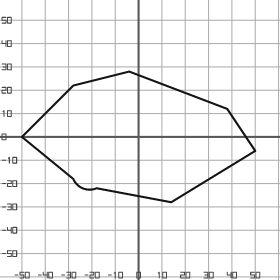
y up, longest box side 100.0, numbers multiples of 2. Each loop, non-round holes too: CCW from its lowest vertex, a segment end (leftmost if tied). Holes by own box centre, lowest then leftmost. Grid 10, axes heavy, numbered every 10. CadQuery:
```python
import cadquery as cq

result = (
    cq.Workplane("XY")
    .moveTo(14.0, -28.0)
    .lineTo(50.0, -6.0)
    .lineTo(38.0, 12.0)
    .lineTo(-4.0, 28.0)
    .lineTo(-28.0, 22.0)
    .lineTo(-50.0, 0.0)
    .lineTo(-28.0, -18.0)
    .threePointArc((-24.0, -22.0), (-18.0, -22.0))
    .close()
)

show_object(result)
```